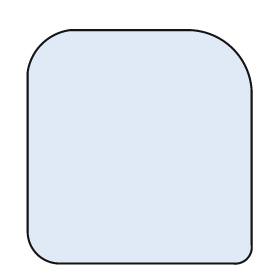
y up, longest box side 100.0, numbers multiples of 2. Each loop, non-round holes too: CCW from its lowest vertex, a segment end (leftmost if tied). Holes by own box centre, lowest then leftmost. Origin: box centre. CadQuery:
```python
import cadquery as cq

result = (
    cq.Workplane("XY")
    .moveTo(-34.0, -50.0)
    .lineTo(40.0, -50.0)
    .threePointArc((46.0, -48.0), (48.0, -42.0))
    .lineTo(48.0, 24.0)
    .threePointArc((40.0, 42.0), (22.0, 50.0))
    .lineTo(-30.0, 50.0)
    .threePointArc((-42.0, 44.0), (-48.0, 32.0))
    .lineTo(-48.0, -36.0)
    .threePointArc((-44.0, -46.0), (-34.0, -50.0))
    .close()
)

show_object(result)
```